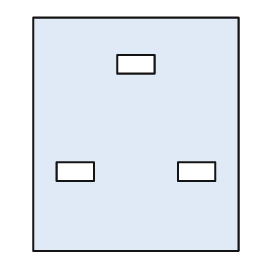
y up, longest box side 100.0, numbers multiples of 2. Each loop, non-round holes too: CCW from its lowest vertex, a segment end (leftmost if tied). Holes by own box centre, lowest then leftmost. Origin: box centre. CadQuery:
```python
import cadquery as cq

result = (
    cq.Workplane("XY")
    .moveTo(-44.0, -50.0)
    .lineTo(44.0, -50.0)
    .lineTo(44.0, 50.0)
    .lineTo(-44.0, 50.0)
    .close()
    .moveTo(-34.0, -20.0)
    .lineTo(-18.0, -20.0)
    .lineTo(-18.0, -12.0)
    .lineTo(-34.0, -12.0)
    .close()
    .moveTo(18.0, -20.0)
    .lineTo(34.0, -20.0)
    .lineTo(34.0, -12.0)
    .lineTo(18.0, -12.0)
    .close()
    .moveTo(-8.0, 26.0)
    .lineTo(8.0, 26.0)
    .lineTo(8.0, 34.0)
    .lineTo(-8.0, 34.0)
    .close()
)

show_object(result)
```